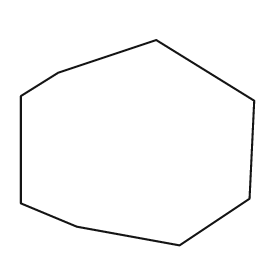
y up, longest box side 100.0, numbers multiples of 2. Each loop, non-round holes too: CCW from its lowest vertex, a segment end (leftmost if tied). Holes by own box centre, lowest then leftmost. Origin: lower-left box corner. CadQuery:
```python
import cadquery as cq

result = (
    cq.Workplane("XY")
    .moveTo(68.0, 0.0)
    .lineTo(98.0, 20.0)
    .lineTo(100.0, 62.0)
    .lineTo(58.0, 88.0)
    .lineTo(16.0, 74.0)
    .lineTo(0.0, 64.0)
    .lineTo(0.0, 18.0)
    .lineTo(24.0, 8.0)
    .close()
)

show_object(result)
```